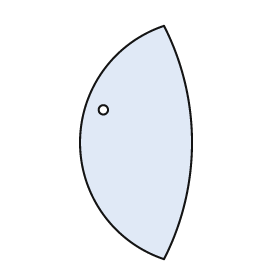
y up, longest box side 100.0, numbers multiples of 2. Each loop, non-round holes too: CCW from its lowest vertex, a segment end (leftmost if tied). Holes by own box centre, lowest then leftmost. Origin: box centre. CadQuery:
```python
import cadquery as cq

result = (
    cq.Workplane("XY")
    .moveTo(12.0, -50.0)
    .threePointArc((24.0, 0.0), (12.0, 50.0))
    .threePointArc((-24.0, 0.0), (12.0, -50.0))
    .close()
    .moveTo(-14.0, 14.0)
    .circle(2.0)
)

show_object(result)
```